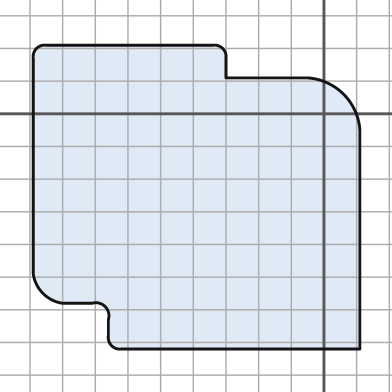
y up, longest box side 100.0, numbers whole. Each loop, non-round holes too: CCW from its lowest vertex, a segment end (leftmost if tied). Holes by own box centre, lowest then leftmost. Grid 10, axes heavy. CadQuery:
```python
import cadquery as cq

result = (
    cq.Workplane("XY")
    .moveTo(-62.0, -72.0)
    .lineTo(11.0, -72.0)
    .lineTo(11.0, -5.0)
    .threePointArc((6.0, 6.0), (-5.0, 11.0))
    .lineTo(-30.0, 11.0)
    .lineTo(-30.0, 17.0)
    .threePointArc((-31.0, 20.0), (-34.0, 21.0))
    .lineTo(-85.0, 21.0)
    .threePointArc((-88.0, 20.0), (-89.0, 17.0))
    .lineTo(-89.0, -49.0)
    .threePointArc((-86.0, -55.0), (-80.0, -58.0))
    .lineTo(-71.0, -58.0)
    .threePointArc((-67.0, -59.0), (-66.0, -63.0))
    .lineTo(-66.0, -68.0)
    .threePointArc((-65.0, -71.0), (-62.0, -72.0))
    .close()
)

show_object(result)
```